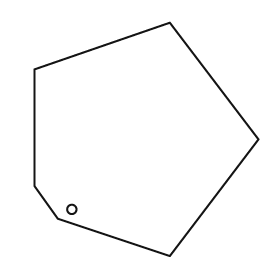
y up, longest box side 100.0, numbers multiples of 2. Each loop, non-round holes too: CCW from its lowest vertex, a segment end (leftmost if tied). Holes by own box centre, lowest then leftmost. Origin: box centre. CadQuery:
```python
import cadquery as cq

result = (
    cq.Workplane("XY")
    .moveTo(10.0, -50.0)
    .lineTo(48.0, 0.0)
    .lineTo(10.0, 50.0)
    .lineTo(-48.0, 30.0)
    .lineTo(-48.0, -20.0)
    .lineTo(-38.0, -34.0)
    .close()
    .moveTo(-32.0, -30.0)
    .circle(2.0)
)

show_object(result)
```